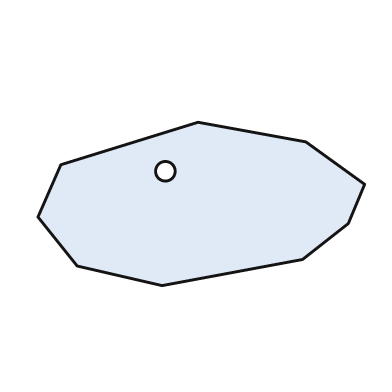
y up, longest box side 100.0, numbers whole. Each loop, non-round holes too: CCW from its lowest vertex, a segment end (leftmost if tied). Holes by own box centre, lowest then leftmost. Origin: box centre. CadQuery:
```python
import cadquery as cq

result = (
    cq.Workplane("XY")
    .moveTo(-12.0, -25.0)
    .lineTo(31.0, -17.0)
    .lineTo(45.0, -6.0)
    .lineTo(50.0, 6.0)
    .lineTo(32.0, 19.0)
    .lineTo(-1.0, 25.0)
    .lineTo(-43.0, 12.0)
    .lineTo(-50.0, -4.0)
    .lineTo(-38.0, -19.0)
    .close()
    .moveTo(-11.0, 10.0)
    .circle(3.0)
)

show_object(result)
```